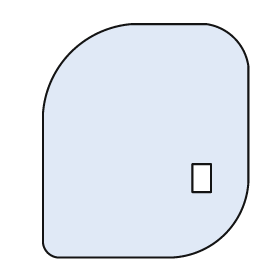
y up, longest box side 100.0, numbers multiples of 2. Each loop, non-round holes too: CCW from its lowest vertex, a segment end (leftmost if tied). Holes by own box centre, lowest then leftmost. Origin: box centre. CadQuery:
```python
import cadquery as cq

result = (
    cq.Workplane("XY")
    .moveTo(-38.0, -50.0)
    .lineTo(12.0, -50.0)
    .threePointArc((34.0, -40.0), (44.0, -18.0))
    .lineTo(44.0, 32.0)
    .threePointArc((38.0, 44.0), (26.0, 50.0))
    .lineTo(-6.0, 50.0)
    .threePointArc((-32.0, 38.0), (-44.0, 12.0))
    .lineTo(-44.0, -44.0)
    .threePointArc((-42.0, -48.0), (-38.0, -50.0))
    .close()
    .moveTo(20.0, -22.0)
    .lineTo(28.0, -22.0)
    .lineTo(28.0, -10.0)
    .lineTo(20.0, -10.0)
    .close()
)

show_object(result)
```